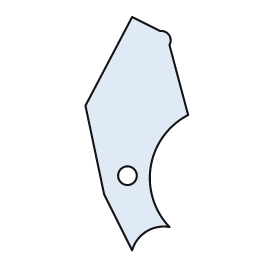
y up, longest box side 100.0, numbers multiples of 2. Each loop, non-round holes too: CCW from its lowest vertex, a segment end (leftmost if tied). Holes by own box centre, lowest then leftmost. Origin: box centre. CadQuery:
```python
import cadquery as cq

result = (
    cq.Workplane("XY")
    .moveTo(-2.0, -50.0)
    .threePointArc((4.0, -42.0), (14.0, -40.0))
    .threePointArc((6.0, -14.0), (22.0, 8.0))
    .lineTo(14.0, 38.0)
    .threePointArc((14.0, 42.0), (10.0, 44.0))
    .lineTo(-2.0, 50.0)
    .lineTo(-22.0, 12.0)
    .lineTo(-14.0, -26.0)
    .close()
    .moveTo(-4.0, -18.0)
    .circle(4.0)
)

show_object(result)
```